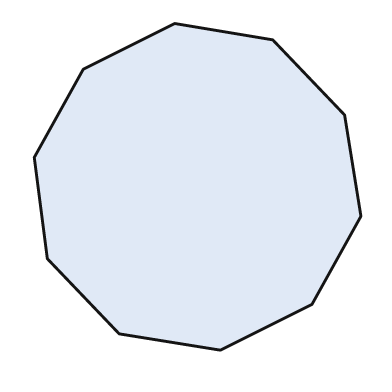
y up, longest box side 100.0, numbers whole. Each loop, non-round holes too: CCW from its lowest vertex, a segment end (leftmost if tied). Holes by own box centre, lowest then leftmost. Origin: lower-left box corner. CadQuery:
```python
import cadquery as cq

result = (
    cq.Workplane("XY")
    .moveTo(57.0, 0.0)
    .lineTo(85.0, 14.0)
    .lineTo(100.0, 41.0)
    .lineTo(95.0, 72.0)
    .lineTo(73.0, 95.0)
    .lineTo(43.0, 100.0)
    .lineTo(15.0, 86.0)
    .lineTo(0.0, 59.0)
    .lineTo(4.0, 28.0)
    .lineTo(26.0, 5.0)
    .close()
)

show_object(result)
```